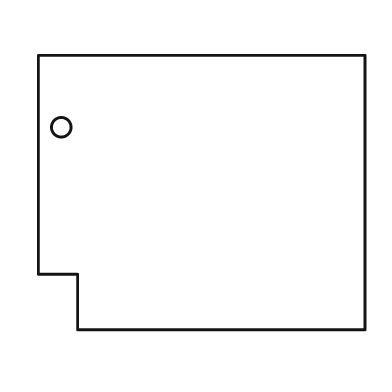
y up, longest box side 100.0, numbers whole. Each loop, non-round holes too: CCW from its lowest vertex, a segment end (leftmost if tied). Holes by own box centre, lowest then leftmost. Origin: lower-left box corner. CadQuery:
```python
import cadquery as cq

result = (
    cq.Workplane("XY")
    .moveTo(12.0, 0.0)
    .lineTo(100.0, 0.0)
    .lineTo(100.0, 84.0)
    .lineTo(0.0, 84.0)
    .lineTo(0.0, 17.0)
    .lineTo(12.0, 17.0)
    .close()
    .moveTo(7.0, 62.0)
    .circle(3.0)
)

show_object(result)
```